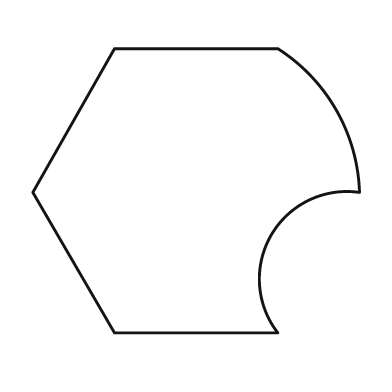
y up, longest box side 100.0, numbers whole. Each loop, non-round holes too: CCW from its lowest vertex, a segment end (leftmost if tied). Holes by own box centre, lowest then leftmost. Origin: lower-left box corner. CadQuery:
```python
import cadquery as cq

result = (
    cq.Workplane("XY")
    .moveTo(25.0, 0.0)
    .lineTo(75.0, 0.0)
    .threePointArc((73.0, 30.0), (100.0, 43.0))
    .threePointArc((93.0, 68.0), (75.0, 87.0))
    .lineTo(25.0, 87.0)
    .lineTo(0.0, 43.0)
    .close()
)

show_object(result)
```